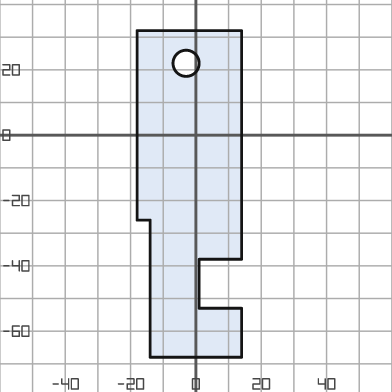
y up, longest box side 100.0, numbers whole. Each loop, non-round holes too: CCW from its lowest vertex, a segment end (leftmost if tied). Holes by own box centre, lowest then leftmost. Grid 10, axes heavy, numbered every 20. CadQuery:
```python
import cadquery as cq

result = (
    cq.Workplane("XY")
    .moveTo(-14.0, -68.0)
    .lineTo(14.0, -68.0)
    .lineTo(14.0, -53.0)
    .lineTo(1.0, -53.0)
    .lineTo(1.0, -38.0)
    .lineTo(14.0, -38.0)
    .lineTo(14.0, 32.0)
    .lineTo(-18.0, 32.0)
    .lineTo(-18.0, -26.0)
    .lineTo(-14.0, -26.0)
    .close()
    .moveTo(-3.0, 22.0)
    .circle(4.0)
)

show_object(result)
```